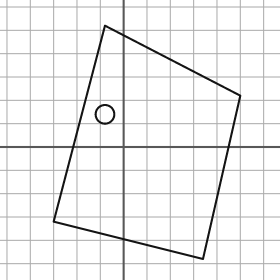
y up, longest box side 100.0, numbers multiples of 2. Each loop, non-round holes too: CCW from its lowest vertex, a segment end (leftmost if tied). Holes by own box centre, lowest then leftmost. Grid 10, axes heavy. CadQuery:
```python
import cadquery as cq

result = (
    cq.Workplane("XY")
    .moveTo(34.0, -48.0)
    .lineTo(50.0, 22.0)
    .lineTo(-8.0, 52.0)
    .lineTo(-30.0, -32.0)
    .close()
    .moveTo(-8.0, 14.0)
    .circle(4.0)
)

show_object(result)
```